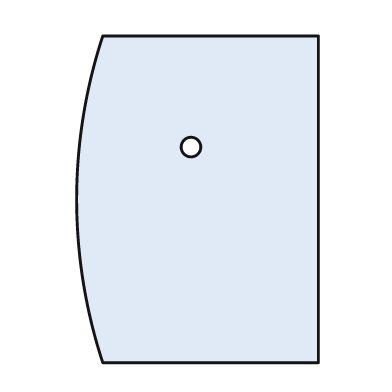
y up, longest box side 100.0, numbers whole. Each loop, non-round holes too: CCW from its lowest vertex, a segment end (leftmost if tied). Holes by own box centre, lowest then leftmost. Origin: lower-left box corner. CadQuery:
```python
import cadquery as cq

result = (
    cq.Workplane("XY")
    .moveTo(8.0, 0.0)
    .lineTo(74.0, 0.0)
    .lineTo(74.0, 100.0)
    .lineTo(8.0, 100.0)
    .threePointArc((0.0, 50.0), (8.0, 0.0))
    .close()
    .moveTo(35.0, 66.0)
    .circle(3.0)
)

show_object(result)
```